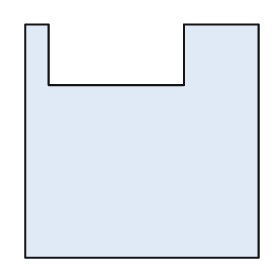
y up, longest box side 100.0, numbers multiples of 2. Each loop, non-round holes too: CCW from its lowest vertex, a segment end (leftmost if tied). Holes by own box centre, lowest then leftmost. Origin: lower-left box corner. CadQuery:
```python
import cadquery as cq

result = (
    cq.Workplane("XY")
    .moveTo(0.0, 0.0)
    .lineTo(100.0, 0.0)
    .lineTo(100.0, 100.0)
    .lineTo(68.0, 100.0)
    .lineTo(68.0, 74.0)
    .lineTo(10.0, 74.0)
    .lineTo(10.0, 100.0)
    .lineTo(0.0, 100.0)
    .close()
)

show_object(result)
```